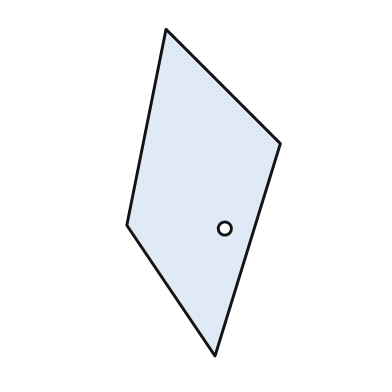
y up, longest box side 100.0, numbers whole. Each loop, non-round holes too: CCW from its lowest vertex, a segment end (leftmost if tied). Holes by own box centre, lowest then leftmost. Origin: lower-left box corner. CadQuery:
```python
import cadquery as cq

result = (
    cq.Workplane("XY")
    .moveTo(27.0, 0.0)
    .lineTo(47.0, 65.0)
    .lineTo(12.0, 100.0)
    .lineTo(0.0, 40.0)
    .close()
    .moveTo(30.0, 39.0)
    .circle(2.0)
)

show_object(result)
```